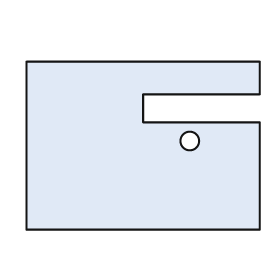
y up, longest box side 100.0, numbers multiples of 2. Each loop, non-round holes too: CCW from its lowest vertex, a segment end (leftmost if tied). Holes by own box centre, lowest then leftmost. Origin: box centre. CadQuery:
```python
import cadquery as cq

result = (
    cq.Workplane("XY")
    .moveTo(-50.0, -36.0)
    .lineTo(50.0, -36.0)
    .lineTo(50.0, 10.0)
    .lineTo(0.0, 10.0)
    .lineTo(0.0, 22.0)
    .lineTo(50.0, 22.0)
    .lineTo(50.0, 36.0)
    .lineTo(-50.0, 36.0)
    .close()
    .moveTo(20.0, 2.0)
    .circle(4.0)
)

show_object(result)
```